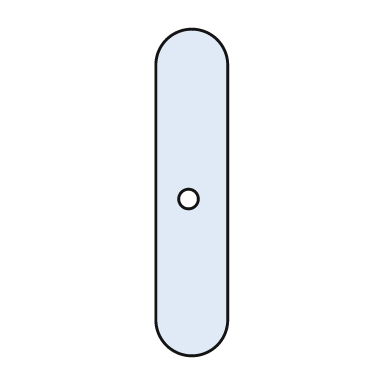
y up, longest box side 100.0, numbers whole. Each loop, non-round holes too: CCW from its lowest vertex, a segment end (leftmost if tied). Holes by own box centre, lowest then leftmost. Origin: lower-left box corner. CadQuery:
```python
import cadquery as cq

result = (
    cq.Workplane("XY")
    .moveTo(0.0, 11.0)
    .threePointArc((11.0, 0.0), (22.0, 11.0))
    .lineTo(22.0, 89.0)
    .threePointArc((11.0, 100.0), (0.0, 89.0))
    .close()
    .moveTo(10.0, 48.0)
    .circle(3.0)
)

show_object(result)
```